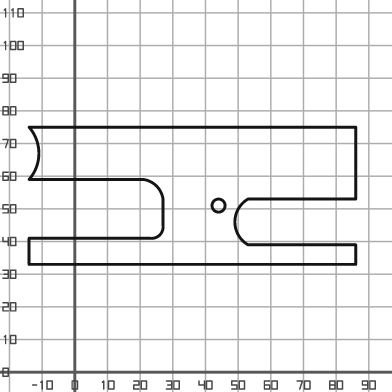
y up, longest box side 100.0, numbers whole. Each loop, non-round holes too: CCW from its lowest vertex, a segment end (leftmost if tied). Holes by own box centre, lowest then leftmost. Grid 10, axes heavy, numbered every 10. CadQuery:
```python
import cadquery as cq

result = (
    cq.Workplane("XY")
    .moveTo(-14.0, 33.0)
    .lineTo(86.0, 33.0)
    .lineTo(86.0, 39.0)
    .lineTo(53.0, 39.0)
    .threePointArc((49.0, 46.0), (53.0, 53.0))
    .lineTo(86.0, 53.0)
    .lineTo(86.0, 75.0)
    .lineTo(-14.0, 75.0)
    .threePointArc((-11.0, 67.0), (-14.0, 59.0))
    .lineTo(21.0, 59.0)
    .threePointArc((25.0, 57.0), (27.0, 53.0))
    .lineTo(27.0, 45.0)
    .threePointArc((26.0, 42.0), (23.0, 41.0))
    .lineTo(-14.0, 41.0)
    .close()
    .moveTo(44.0, 51.0)
    .circle(2.0)
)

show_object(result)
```